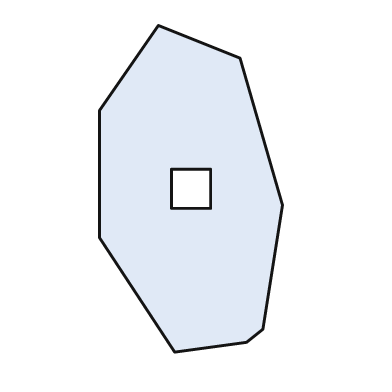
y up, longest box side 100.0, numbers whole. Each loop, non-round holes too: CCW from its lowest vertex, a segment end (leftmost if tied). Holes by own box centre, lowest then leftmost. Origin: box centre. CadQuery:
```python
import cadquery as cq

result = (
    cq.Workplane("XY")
    .moveTo(-5.0, -50.0)
    .lineTo(17.0, -47.0)
    .lineTo(22.0, -43.0)
    .lineTo(28.0, -5.0)
    .lineTo(15.0, 40.0)
    .lineTo(-10.0, 50.0)
    .lineTo(-28.0, 24.0)
    .lineTo(-28.0, -15.0)
    .close()
    .moveTo(-6.0, -6.0)
    .lineTo(6.0, -6.0)
    .lineTo(6.0, 6.0)
    .lineTo(-6.0, 6.0)
    .close()
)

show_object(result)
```